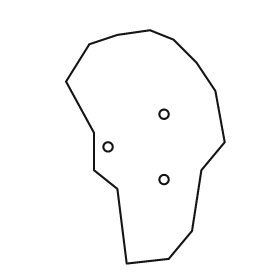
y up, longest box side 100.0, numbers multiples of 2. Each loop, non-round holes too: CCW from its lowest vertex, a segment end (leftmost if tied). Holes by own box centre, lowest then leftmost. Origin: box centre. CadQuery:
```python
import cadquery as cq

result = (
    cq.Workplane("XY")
    .moveTo(-8.0, -50.0)
    .lineTo(10.0, -48.0)
    .lineTo(20.0, -36.0)
    .lineTo(24.0, -10.0)
    .lineTo(34.0, 2.0)
    .lineTo(30.0, 24.0)
    .lineTo(22.0, 36.0)
    .lineTo(12.0, 46.0)
    .lineTo(2.0, 50.0)
    .lineTo(-12.0, 48.0)
    .lineTo(-24.0, 44.0)
    .lineTo(-34.0, 28.0)
    .lineTo(-22.0, 6.0)
    .lineTo(-22.0, -10.0)
    .lineTo(-12.0, -18.0)
    .close()
    .moveTo(8.0, -14.0)
    .circle(2.0)
    .moveTo(-16.0, 0.0)
    .circle(2.0)
    .moveTo(8.0, 14.0)
    .circle(2.0)
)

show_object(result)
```